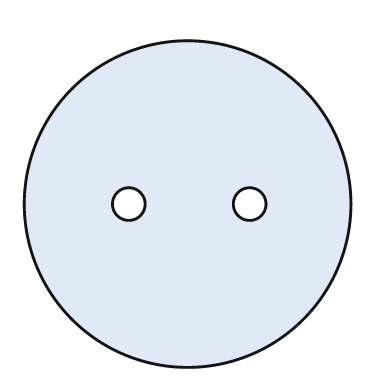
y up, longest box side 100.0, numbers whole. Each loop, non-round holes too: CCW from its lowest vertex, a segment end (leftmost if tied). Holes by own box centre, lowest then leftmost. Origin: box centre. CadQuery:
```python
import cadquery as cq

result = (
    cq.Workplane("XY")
    .moveTo(0.0, 0.0)
    .circle(50.0)
    .moveTo(-18.0, 0.0)
    .circle(5.0)
    .moveTo(19.0, 0.0)
    .circle(5.0)
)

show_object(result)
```